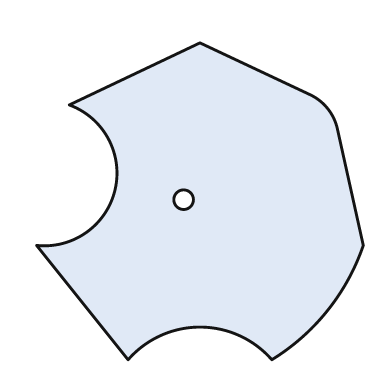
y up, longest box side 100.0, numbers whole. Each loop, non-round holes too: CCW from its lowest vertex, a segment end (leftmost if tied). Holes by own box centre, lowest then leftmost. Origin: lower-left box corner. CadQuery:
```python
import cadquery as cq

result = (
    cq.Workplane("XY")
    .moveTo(28.0, 0.0)
    .threePointArc((50.0, 10.0), (72.0, 0.0))
    .threePointArc((89.0, 15.0), (100.0, 35.0))
    .lineTo(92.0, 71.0)
    .threePointArc((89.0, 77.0), (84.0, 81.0))
    .lineTo(50.0, 97.0)
    .lineTo(10.0, 78.0)
    .threePointArc((24.0, 52.0), (0.0, 35.0))
    .close()
    .moveTo(45.0, 49.0)
    .circle(3.0)
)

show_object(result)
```